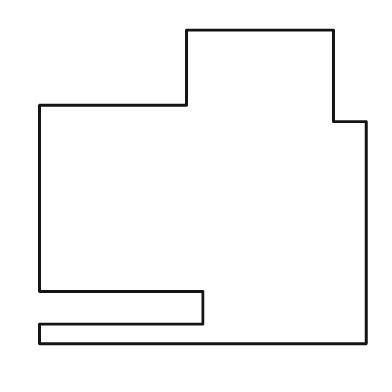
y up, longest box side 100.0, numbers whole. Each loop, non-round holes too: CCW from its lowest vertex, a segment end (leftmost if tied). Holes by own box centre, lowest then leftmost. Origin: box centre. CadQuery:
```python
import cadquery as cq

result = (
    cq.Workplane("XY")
    .moveTo(-50.0, -48.0)
    .lineTo(50.0, -48.0)
    .lineTo(50.0, 20.0)
    .lineTo(40.0, 20.0)
    .lineTo(40.0, 48.0)
    .lineTo(-5.0, 48.0)
    .lineTo(-5.0, 25.0)
    .lineTo(-50.0, 25.0)
    .lineTo(-50.0, -32.0)
    .lineTo(0.0, -32.0)
    .lineTo(0.0, -42.0)
    .lineTo(-50.0, -42.0)
    .close()
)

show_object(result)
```